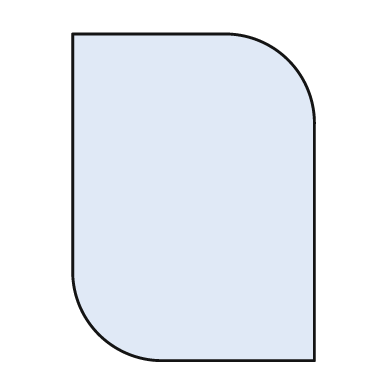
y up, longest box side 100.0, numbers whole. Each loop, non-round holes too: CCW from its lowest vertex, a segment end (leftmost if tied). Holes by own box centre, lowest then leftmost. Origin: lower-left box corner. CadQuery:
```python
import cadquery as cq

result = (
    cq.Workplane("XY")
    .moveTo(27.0, 0.0)
    .lineTo(74.0, 0.0)
    .lineTo(74.0, 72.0)
    .threePointArc((66.0, 92.0), (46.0, 100.0))
    .lineTo(0.0, 100.0)
    .lineTo(0.0, 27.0)
    .threePointArc((8.0, 8.0), (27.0, 0.0))
    .close()
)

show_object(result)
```